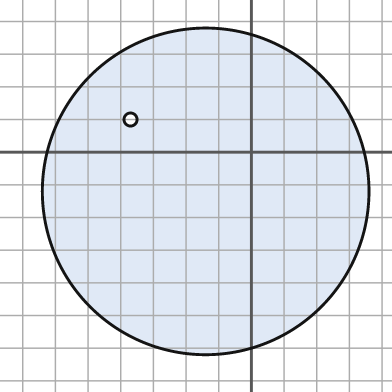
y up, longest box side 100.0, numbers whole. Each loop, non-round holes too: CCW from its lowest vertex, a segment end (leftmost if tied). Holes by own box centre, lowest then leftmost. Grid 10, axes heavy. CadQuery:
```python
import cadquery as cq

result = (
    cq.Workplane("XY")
    .moveTo(-14.0, -12.0)
    .circle(50.0)
    .moveTo(-37.0, 10.0)
    .circle(2.0)
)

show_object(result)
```